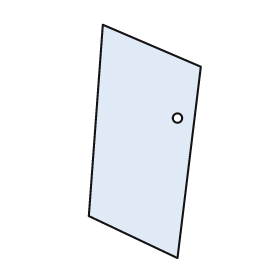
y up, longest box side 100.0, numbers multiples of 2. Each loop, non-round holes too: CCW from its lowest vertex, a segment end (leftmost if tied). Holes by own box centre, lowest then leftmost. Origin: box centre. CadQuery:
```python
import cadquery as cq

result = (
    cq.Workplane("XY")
    .moveTo(14.0, -50.0)
    .lineTo(24.0, 32.0)
    .lineTo(-18.0, 50.0)
    .lineTo(-24.0, -32.0)
    .close()
    .moveTo(14.0, 10.0)
    .circle(2.0)
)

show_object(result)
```